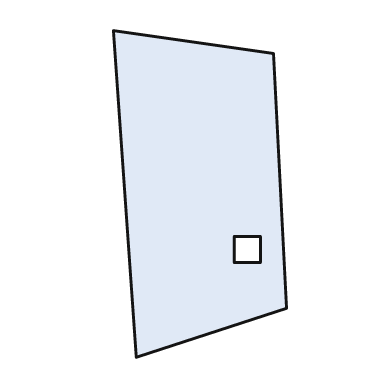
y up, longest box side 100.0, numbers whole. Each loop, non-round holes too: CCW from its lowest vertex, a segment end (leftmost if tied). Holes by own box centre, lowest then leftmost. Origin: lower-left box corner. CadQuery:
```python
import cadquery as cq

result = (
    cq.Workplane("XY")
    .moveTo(7.0, 0.0)
    .lineTo(53.0, 15.0)
    .lineTo(49.0, 93.0)
    .lineTo(0.0, 100.0)
    .close()
    .moveTo(37.0, 29.0)
    .lineTo(45.0, 29.0)
    .lineTo(45.0, 37.0)
    .lineTo(37.0, 37.0)
    .close()
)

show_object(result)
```